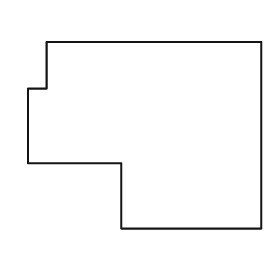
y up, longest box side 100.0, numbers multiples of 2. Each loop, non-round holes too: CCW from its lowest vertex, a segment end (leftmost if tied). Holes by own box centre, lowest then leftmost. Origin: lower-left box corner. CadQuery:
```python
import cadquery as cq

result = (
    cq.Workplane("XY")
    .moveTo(40.0, 0.0)
    .lineTo(100.0, 0.0)
    .lineTo(100.0, 80.0)
    .lineTo(8.0, 80.0)
    .lineTo(8.0, 60.0)
    .lineTo(0.0, 60.0)
    .lineTo(0.0, 28.0)
    .lineTo(40.0, 28.0)
    .close()
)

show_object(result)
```